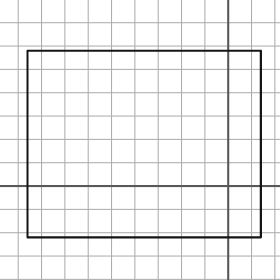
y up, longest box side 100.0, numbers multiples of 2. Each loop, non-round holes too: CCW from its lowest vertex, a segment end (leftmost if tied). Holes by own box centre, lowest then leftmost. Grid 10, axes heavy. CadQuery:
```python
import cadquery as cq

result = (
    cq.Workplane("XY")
    .moveTo(-86.0, -22.0)
    .lineTo(14.0, -22.0)
    .lineTo(14.0, 58.0)
    .lineTo(-86.0, 58.0)
    .close()
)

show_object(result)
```